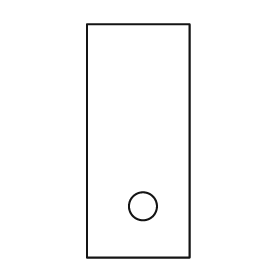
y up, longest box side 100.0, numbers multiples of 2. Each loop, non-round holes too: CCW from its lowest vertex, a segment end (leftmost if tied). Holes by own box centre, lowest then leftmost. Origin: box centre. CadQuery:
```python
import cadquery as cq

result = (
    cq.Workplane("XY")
    .moveTo(-22.0, -50.0)
    .lineTo(22.0, -50.0)
    .lineTo(22.0, 50.0)
    .lineTo(-22.0, 50.0)
    .close()
    .moveTo(2.0, -28.0)
    .circle(6.0)
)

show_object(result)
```